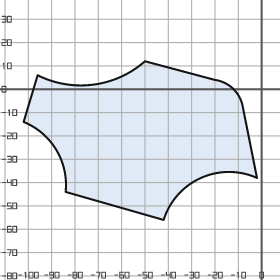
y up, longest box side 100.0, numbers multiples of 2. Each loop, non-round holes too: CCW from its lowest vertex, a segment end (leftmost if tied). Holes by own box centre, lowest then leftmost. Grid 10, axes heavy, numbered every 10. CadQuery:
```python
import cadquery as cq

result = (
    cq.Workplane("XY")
    .moveTo(-42.0, -56.0)
    .threePointArc((-26.0, -38.0), (-2.0, -38.0))
    .lineTo(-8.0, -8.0)
    .threePointArc((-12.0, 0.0), (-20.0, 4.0))
    .lineTo(-50.0, 12.0)
    .threePointArc((-72.0, 2.0), (-96.0, 6.0))
    .lineTo(-102.0, -14.0)
    .threePointArc((-88.0, -26.0), (-84.0, -44.0))
    .close()
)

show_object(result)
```